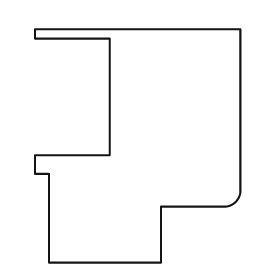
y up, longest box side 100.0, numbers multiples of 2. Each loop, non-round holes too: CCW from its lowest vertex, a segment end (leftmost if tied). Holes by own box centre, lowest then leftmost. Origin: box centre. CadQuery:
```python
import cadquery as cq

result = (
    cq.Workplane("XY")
    .moveTo(-38.0, -50.0)
    .lineTo(10.0, -50.0)
    .lineTo(10.0, -26.0)
    .lineTo(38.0, -26.0)
    .threePointArc((42.0, -24.0), (44.0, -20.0))
    .lineTo(44.0, 50.0)
    .lineTo(-44.0, 50.0)
    .lineTo(-44.0, 46.0)
    .lineTo(-12.0, 46.0)
    .lineTo(-12.0, -4.0)
    .lineTo(-44.0, -4.0)
    .lineTo(-44.0, -12.0)
    .lineTo(-38.0, -12.0)
    .close()
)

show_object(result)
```